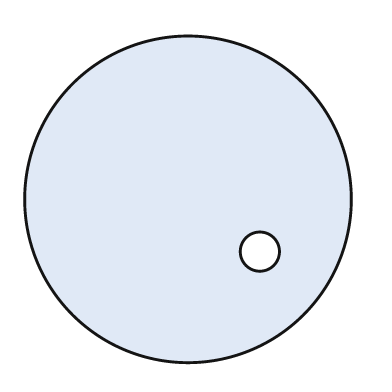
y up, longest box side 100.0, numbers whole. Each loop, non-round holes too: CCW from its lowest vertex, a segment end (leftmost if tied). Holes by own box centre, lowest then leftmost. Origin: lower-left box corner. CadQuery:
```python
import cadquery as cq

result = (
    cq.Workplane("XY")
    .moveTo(50.0, 50.0)
    .circle(50.0)
    .moveTo(72.0, 34.0)
    .circle(6.0)
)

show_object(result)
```